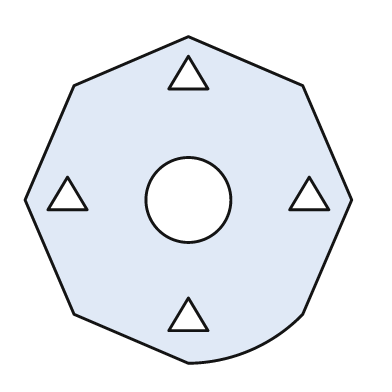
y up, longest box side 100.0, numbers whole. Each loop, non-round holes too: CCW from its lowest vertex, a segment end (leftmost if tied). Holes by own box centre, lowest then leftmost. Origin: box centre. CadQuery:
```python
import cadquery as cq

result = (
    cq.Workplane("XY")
    .moveTo(0.0, -50.0)
    .threePointArc((19.0, -46.0), (35.0, -35.0))
    .lineTo(50.0, 0.0)
    .lineTo(35.0, 35.0)
    .lineTo(0.0, 50.0)
    .lineTo(-35.0, 35.0)
    .lineTo(-50.0, 0.0)
    .lineTo(-35.0, -35.0)
    .close()
    .moveTo(-6.0, -40.0)
    .lineTo(6.0, -40.0)
    .lineTo(0.0, -30.0)
    .close()
    .moveTo(0.0, 0.0)
    .circle(13.0)
    .moveTo(-43.0, -3.0)
    .lineTo(-31.0, -3.0)
    .lineTo(-37.0, 7.0)
    .close()
    .moveTo(31.0, -3.0)
    .lineTo(43.0, -3.0)
    .lineTo(37.0, 7.0)
    .close()
    .moveTo(-6.0, 34.0)
    .lineTo(6.0, 34.0)
    .lineTo(0.0, 44.0)
    .close()
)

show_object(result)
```